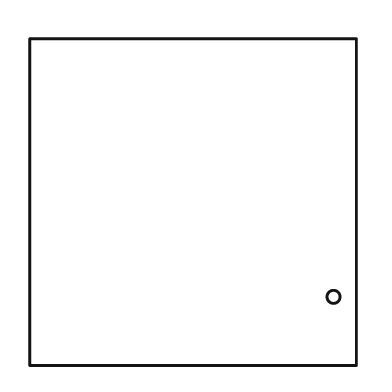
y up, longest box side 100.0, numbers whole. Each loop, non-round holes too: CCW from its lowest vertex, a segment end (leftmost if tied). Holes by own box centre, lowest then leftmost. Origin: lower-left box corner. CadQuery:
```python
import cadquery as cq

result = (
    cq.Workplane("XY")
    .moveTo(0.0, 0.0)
    .lineTo(100.0, 0.0)
    .lineTo(100.0, 100.0)
    .lineTo(0.0, 100.0)
    .close()
    .moveTo(93.0, 21.0)
    .circle(2.0)
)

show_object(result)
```